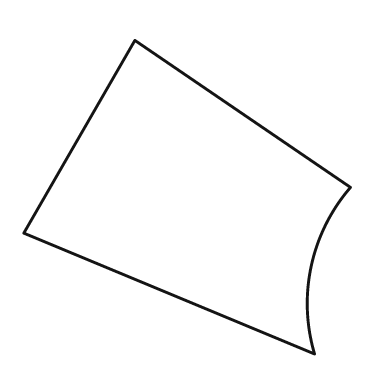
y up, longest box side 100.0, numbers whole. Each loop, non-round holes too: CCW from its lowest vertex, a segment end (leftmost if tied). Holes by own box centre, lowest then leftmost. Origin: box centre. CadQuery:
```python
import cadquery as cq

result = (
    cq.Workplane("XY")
    .moveTo(39.0, -48.0)
    .threePointArc((38.0, -21.0), (50.0, 3.0))
    .lineTo(-16.0, 48.0)
    .lineTo(-50.0, -11.0)
    .close()
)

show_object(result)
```